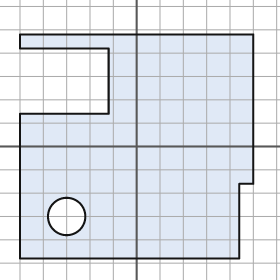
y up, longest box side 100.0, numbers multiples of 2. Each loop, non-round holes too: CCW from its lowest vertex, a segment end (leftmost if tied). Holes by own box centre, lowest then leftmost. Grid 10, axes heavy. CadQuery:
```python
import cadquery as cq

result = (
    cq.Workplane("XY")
    .moveTo(-50.0, -48.0)
    .lineTo(44.0, -48.0)
    .lineTo(44.0, -16.0)
    .lineTo(50.0, -16.0)
    .lineTo(50.0, 48.0)
    .lineTo(-50.0, 48.0)
    .lineTo(-50.0, 42.0)
    .lineTo(-12.0, 42.0)
    .lineTo(-12.0, 14.0)
    .lineTo(-50.0, 14.0)
    .close()
    .moveTo(-30.0, -30.0)
    .circle(8.0)
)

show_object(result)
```